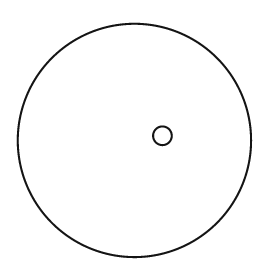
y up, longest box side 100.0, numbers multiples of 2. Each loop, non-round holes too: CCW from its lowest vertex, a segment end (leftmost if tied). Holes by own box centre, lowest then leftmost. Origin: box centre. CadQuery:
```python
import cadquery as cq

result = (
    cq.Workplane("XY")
    .moveTo(0.0, 0.0)
    .circle(50.0)
    .moveTo(12.0, 2.0)
    .circle(4.0)
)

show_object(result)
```